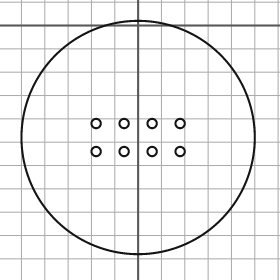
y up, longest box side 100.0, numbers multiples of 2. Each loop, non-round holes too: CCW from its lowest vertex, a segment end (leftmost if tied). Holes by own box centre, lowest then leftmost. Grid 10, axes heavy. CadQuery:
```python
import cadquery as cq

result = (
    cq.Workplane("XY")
    .moveTo(0.0, -48.0)
    .circle(50.0)
    .moveTo(-18.0, -54.0)
    .circle(2.0)
    .moveTo(-6.0, -54.0)
    .circle(2.0)
    .moveTo(6.0, -54.0)
    .circle(2.0)
    .moveTo(18.0, -54.0)
    .circle(2.0)
    .moveTo(-18.0, -42.0)
    .circle(2.0)
    .moveTo(-6.0, -42.0)
    .circle(2.0)
    .moveTo(6.0, -42.0)
    .circle(2.0)
    .moveTo(18.0, -42.0)
    .circle(2.0)
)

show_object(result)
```